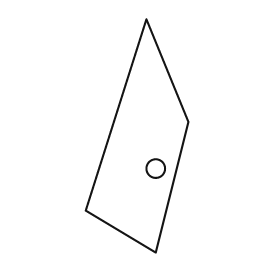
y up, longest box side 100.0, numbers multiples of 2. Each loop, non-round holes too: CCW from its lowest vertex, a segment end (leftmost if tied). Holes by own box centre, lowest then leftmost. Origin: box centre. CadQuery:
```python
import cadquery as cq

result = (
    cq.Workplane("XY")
    .moveTo(8.0, -50.0)
    .lineTo(22.0, 6.0)
    .lineTo(4.0, 50.0)
    .lineTo(-22.0, -32.0)
    .close()
    .moveTo(8.0, -14.0)
    .circle(4.0)
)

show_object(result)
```